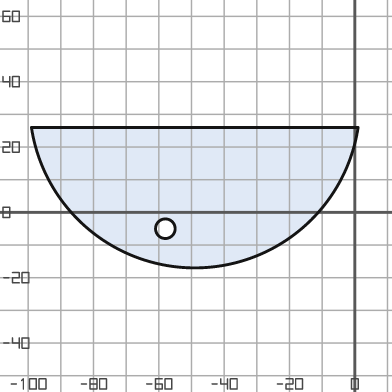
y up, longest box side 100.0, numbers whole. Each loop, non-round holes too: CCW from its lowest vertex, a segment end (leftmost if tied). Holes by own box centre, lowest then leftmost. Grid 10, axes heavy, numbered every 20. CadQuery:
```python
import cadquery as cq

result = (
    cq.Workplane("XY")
    .moveTo(-99.0, 26.0)
    .threePointArc((-49.0, -17.0), (1.0, 26.0))
    .close()
    .moveTo(-58.0, -5.0)
    .circle(3.0)
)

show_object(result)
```